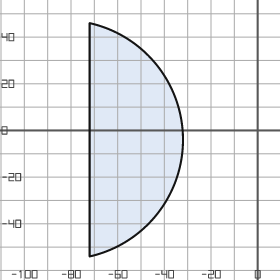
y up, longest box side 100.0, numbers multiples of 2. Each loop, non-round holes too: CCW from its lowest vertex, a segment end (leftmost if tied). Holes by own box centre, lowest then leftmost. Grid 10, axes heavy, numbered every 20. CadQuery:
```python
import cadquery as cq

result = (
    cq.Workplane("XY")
    .moveTo(-72.0, -54.0)
    .threePointArc((-32.0, -4.0), (-72.0, 46.0))
    .close()
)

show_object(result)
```